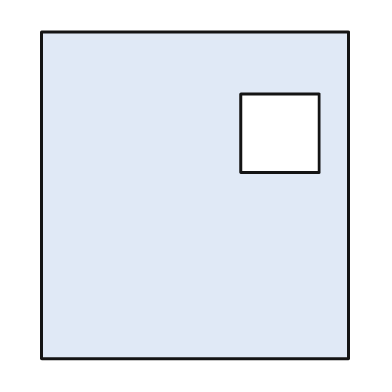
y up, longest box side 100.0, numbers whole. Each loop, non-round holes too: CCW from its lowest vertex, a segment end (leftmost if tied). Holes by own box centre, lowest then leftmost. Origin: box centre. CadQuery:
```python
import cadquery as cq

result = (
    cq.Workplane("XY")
    .moveTo(-47.0, -50.0)
    .lineTo(47.0, -50.0)
    .lineTo(47.0, 50.0)
    .lineTo(-47.0, 50.0)
    .close()
    .moveTo(14.0, 7.0)
    .lineTo(38.0, 7.0)
    .lineTo(38.0, 31.0)
    .lineTo(14.0, 31.0)
    .close()
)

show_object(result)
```